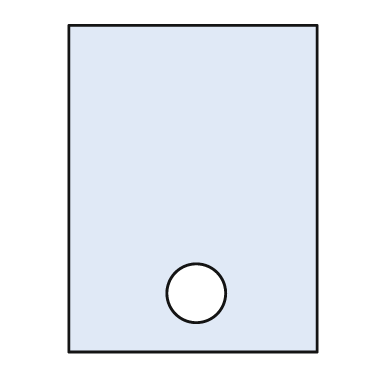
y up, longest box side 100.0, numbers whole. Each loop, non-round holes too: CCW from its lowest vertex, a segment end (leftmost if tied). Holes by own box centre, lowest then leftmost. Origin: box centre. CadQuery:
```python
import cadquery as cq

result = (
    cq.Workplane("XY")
    .moveTo(-38.0, -50.0)
    .lineTo(38.0, -50.0)
    .lineTo(38.0, 50.0)
    .lineTo(-38.0, 50.0)
    .close()
    .moveTo(1.0, -32.0)
    .circle(9.0)
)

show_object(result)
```